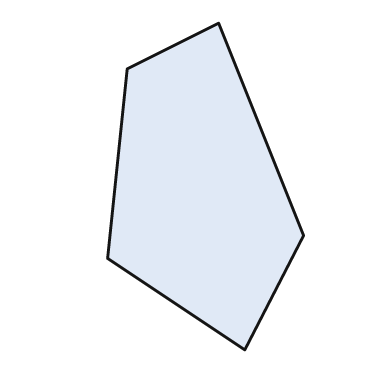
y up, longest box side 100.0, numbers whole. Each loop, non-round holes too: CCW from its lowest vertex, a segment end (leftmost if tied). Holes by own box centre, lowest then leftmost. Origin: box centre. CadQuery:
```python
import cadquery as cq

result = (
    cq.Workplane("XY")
    .moveTo(12.0, -50.0)
    .lineTo(30.0, -15.0)
    .lineTo(4.0, 50.0)
    .lineTo(-24.0, 36.0)
    .lineTo(-30.0, -22.0)
    .close()
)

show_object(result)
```